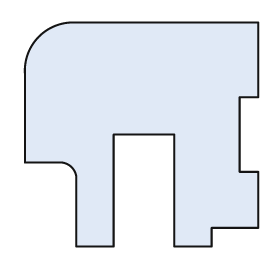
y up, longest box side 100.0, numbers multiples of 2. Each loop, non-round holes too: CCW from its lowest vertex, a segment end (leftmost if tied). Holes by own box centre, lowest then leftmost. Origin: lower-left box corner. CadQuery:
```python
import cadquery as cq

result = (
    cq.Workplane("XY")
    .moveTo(22.0, 0.0)
    .lineTo(38.0, 0.0)
    .lineTo(38.0, 48.0)
    .lineTo(64.0, 48.0)
    .lineTo(64.0, 0.0)
    .lineTo(80.0, 0.0)
    .lineTo(80.0, 8.0)
    .lineTo(100.0, 8.0)
    .lineTo(100.0, 32.0)
    .lineTo(92.0, 32.0)
    .lineTo(92.0, 64.0)
    .lineTo(100.0, 64.0)
    .lineTo(100.0, 96.0)
    .lineTo(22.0, 96.0)
    .threePointArc((6.0, 90.0), (0.0, 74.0))
    .lineTo(0.0, 36.0)
    .lineTo(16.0, 36.0)
    .threePointArc((20.0, 34.0), (22.0, 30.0))
    .close()
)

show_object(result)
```